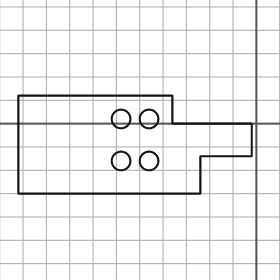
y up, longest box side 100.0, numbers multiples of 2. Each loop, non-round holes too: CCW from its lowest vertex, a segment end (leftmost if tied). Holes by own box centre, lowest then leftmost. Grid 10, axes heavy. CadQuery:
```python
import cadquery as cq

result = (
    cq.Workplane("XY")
    .moveTo(-102.0, -30.0)
    .lineTo(-24.0, -30.0)
    .lineTo(-24.0, -14.0)
    .lineTo(-2.0, -14.0)
    .lineTo(-2.0, 0.0)
    .lineTo(-36.0, 0.0)
    .lineTo(-36.0, 12.0)
    .lineTo(-102.0, 12.0)
    .close()
    .moveTo(-58.0, -16.0)
    .circle(4.0)
    .moveTo(-46.0, -16.0)
    .circle(4.0)
    .moveTo(-58.0, 2.0)
    .circle(4.0)
    .moveTo(-46.0, 2.0)
    .circle(4.0)
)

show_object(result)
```